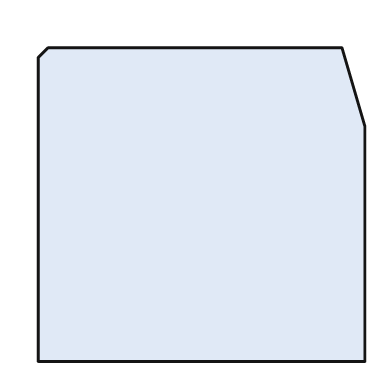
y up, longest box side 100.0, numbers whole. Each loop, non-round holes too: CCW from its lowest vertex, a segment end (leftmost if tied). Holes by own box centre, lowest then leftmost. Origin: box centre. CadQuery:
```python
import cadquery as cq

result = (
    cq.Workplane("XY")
    .moveTo(-50.0, -48.0)
    .lineTo(50.0, -48.0)
    .lineTo(50.0, 24.0)
    .lineTo(43.0, 48.0)
    .lineTo(-47.0, 48.0)
    .lineTo(-50.0, 45.0)
    .close()
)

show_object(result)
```